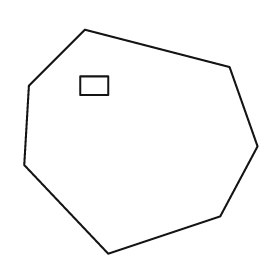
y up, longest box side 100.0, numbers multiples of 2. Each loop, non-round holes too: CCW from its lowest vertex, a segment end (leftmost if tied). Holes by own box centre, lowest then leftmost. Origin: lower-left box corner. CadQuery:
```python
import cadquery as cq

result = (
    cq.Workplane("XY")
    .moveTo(36.0, 0.0)
    .lineTo(84.0, 16.0)
    .lineTo(100.0, 46.0)
    .lineTo(88.0, 80.0)
    .lineTo(26.0, 96.0)
    .lineTo(2.0, 72.0)
    .lineTo(0.0, 38.0)
    .close()
    .moveTo(24.0, 68.0)
    .lineTo(36.0, 68.0)
    .lineTo(36.0, 76.0)
    .lineTo(24.0, 76.0)
    .close()
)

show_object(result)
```